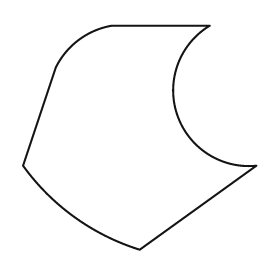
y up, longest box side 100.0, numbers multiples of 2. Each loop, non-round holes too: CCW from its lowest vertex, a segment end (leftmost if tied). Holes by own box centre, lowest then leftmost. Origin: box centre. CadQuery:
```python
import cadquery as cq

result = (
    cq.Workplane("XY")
    .moveTo(0.0, -48.0)
    .lineTo(50.0, -12.0)
    .threePointArc((16.0, 10.0), (30.0, 48.0))
    .lineTo(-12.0, 48.0)
    .threePointArc((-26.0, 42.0), (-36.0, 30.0))
    .lineTo(-50.0, -12.0)
    .threePointArc((-28.0, -34.0), (0.0, -48.0))
    .close()
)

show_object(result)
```